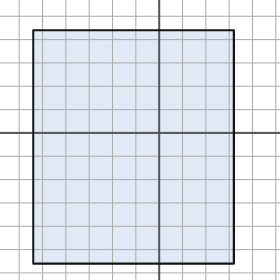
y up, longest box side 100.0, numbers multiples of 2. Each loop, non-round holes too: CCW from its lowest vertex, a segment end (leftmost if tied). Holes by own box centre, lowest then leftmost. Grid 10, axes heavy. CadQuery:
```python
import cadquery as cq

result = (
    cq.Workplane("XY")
    .moveTo(-54.0, -56.0)
    .lineTo(32.0, -56.0)
    .lineTo(32.0, 44.0)
    .lineTo(-54.0, 44.0)
    .close()
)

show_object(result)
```